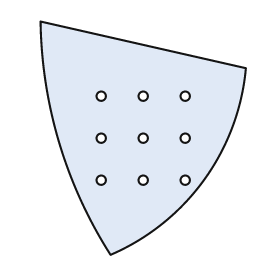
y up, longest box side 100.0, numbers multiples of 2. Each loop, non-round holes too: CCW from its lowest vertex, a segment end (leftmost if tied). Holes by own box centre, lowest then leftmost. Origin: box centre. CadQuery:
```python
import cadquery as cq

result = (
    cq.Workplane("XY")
    .moveTo(-14.0, -50.0)
    .threePointArc((26.0, -18.0), (44.0, 30.0))
    .lineTo(-44.0, 50.0)
    .threePointArc((-36.0, -2.0), (-14.0, -50.0))
    .close()
    .moveTo(-18.0, -18.0)
    .circle(2.0)
    .moveTo(0.0, -18.0)
    .circle(2.0)
    .moveTo(18.0, -18.0)
    .circle(2.0)
    .moveTo(-18.0, 0.0)
    .circle(2.0)
    .moveTo(0.0, 0.0)
    .circle(2.0)
    .moveTo(18.0, 0.0)
    .circle(2.0)
    .moveTo(-18.0, 18.0)
    .circle(2.0)
    .moveTo(0.0, 18.0)
    .circle(2.0)
    .moveTo(18.0, 18.0)
    .circle(2.0)
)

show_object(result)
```